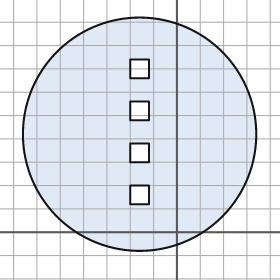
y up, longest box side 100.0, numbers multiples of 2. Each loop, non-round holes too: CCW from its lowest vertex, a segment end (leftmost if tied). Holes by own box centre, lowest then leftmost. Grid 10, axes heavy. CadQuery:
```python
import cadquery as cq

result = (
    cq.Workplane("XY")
    .moveTo(-16.0, 42.0)
    .circle(50.0)
    .moveTo(-20.0, 12.0)
    .lineTo(-12.0, 12.0)
    .lineTo(-12.0, 20.0)
    .lineTo(-20.0, 20.0)
    .close()
    .moveTo(-20.0, 30.0)
    .lineTo(-12.0, 30.0)
    .lineTo(-12.0, 38.0)
    .lineTo(-20.0, 38.0)
    .close()
    .moveTo(-20.0, 48.0)
    .lineTo(-12.0, 48.0)
    .lineTo(-12.0, 56.0)
    .lineTo(-20.0, 56.0)
    .close()
    .moveTo(-20.0, 66.0)
    .lineTo(-12.0, 66.0)
    .lineTo(-12.0, 74.0)
    .lineTo(-20.0, 74.0)
    .close()
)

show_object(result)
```